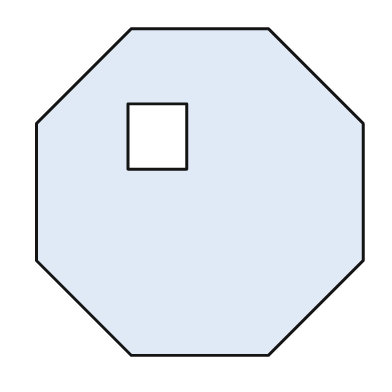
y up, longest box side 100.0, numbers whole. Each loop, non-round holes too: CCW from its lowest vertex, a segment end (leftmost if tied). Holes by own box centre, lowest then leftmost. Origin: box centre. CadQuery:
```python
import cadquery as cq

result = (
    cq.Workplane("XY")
    .moveTo(-21.0, -50.0)
    .lineTo(21.0, -50.0)
    .lineTo(50.0, -21.0)
    .lineTo(50.0, 21.0)
    .lineTo(21.0, 50.0)
    .lineTo(-21.0, 50.0)
    .lineTo(-50.0, 21.0)
    .lineTo(-50.0, -21.0)
    .close()
    .moveTo(-22.0, 7.0)
    .lineTo(-4.0, 7.0)
    .lineTo(-4.0, 27.0)
    .lineTo(-22.0, 27.0)
    .close()
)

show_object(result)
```